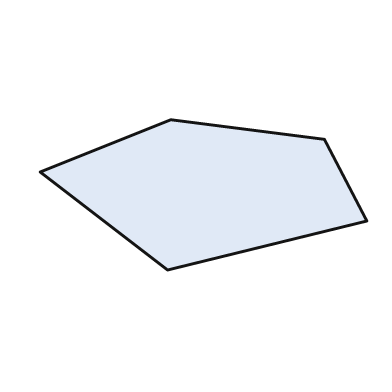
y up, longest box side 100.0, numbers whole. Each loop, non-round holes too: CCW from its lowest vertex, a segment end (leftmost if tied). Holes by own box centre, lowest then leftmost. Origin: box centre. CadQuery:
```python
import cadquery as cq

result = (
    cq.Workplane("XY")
    .moveTo(-11.0, -23.0)
    .lineTo(50.0, -8.0)
    .lineTo(37.0, 17.0)
    .lineTo(-10.0, 23.0)
    .lineTo(-50.0, 7.0)
    .close()
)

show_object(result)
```